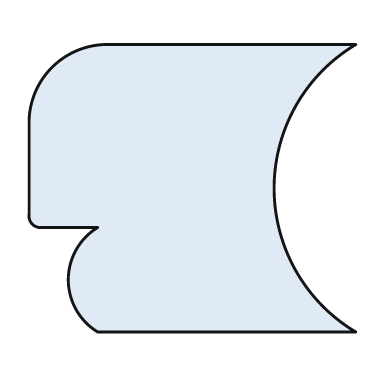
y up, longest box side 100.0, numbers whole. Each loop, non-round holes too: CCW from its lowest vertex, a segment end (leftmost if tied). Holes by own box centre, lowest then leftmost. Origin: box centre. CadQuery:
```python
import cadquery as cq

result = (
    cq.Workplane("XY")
    .moveTo(-29.0, -44.0)
    .lineTo(50.0, -44.0)
    .threePointArc((25.0, 0.0), (50.0, 44.0))
    .lineTo(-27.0, 44.0)
    .threePointArc((-43.0, 37.0), (-50.0, 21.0))
    .lineTo(-50.0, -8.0)
    .threePointArc((-49.0, -11.0), (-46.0, -12.0))
    .lineTo(-29.0, -12.0)
    .threePointArc((-38.0, -28.0), (-29.0, -44.0))
    .close()
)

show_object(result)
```